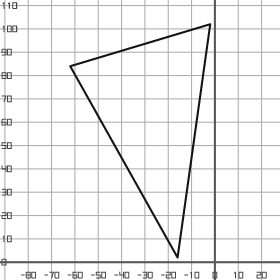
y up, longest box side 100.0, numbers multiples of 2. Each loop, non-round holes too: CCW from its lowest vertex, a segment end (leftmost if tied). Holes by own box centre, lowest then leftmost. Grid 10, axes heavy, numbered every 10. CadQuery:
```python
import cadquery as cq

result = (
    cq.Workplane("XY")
    .moveTo(-16.0, 2.0)
    .lineTo(-2.0, 102.0)
    .lineTo(-62.0, 84.0)
    .close()
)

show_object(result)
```